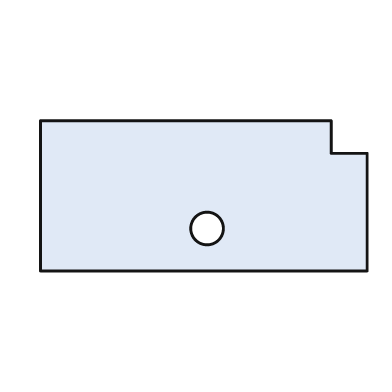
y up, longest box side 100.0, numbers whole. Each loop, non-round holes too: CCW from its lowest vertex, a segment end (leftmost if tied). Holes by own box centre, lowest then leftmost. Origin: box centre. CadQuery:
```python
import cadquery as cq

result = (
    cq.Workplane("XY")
    .moveTo(-50.0, -23.0)
    .lineTo(50.0, -23.0)
    .lineTo(50.0, 13.0)
    .lineTo(39.0, 13.0)
    .lineTo(39.0, 23.0)
    .lineTo(-50.0, 23.0)
    .close()
    .moveTo(1.0, -10.0)
    .circle(5.0)
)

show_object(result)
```